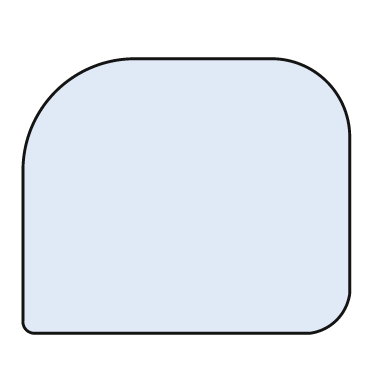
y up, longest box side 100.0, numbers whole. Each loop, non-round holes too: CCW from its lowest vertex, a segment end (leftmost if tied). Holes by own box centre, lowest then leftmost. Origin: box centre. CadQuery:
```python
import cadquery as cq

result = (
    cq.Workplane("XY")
    .moveTo(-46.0, -42.0)
    .lineTo(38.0, -42.0)
    .threePointArc((46.0, -38.0), (50.0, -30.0))
    .lineTo(50.0, 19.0)
    .threePointArc((43.0, 35.0), (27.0, 42.0))
    .lineTo(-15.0, 42.0)
    .threePointArc((-40.0, 32.0), (-50.0, 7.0))
    .lineTo(-50.0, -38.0)
    .threePointArc((-49.0, -41.0), (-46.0, -42.0))
    .close()
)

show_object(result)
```